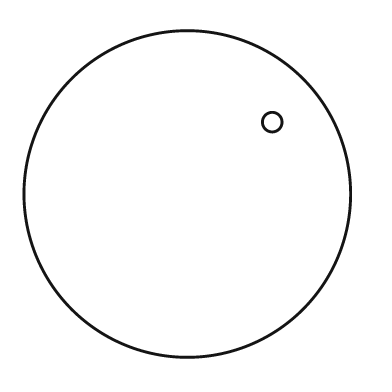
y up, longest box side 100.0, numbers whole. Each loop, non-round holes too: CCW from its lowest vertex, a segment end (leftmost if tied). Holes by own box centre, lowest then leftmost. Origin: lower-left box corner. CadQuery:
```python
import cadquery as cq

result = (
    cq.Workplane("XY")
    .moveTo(50.0, 50.0)
    .circle(50.0)
    .moveTo(76.0, 72.0)
    .circle(3.0)
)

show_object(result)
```